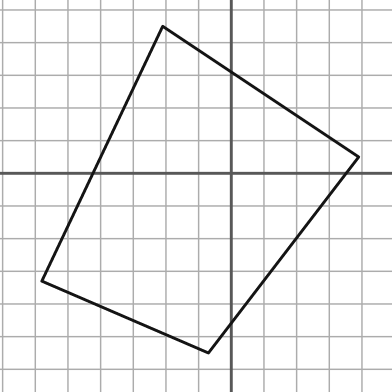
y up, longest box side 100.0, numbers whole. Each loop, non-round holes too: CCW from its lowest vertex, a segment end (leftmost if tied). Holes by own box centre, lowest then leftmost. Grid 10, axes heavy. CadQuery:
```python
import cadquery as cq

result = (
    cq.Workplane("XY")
    .moveTo(-7.0, -55.0)
    .lineTo(39.0, 5.0)
    .lineTo(-21.0, 45.0)
    .lineTo(-58.0, -33.0)
    .close()
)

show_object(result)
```